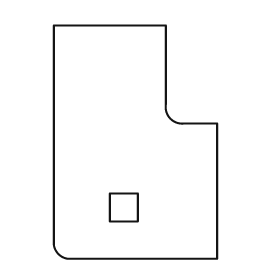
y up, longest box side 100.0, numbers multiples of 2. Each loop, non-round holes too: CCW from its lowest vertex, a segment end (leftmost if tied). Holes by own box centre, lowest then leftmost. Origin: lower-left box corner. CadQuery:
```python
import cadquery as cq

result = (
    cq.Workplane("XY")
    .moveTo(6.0, 0.0)
    .lineTo(70.0, 0.0)
    .lineTo(70.0, 58.0)
    .lineTo(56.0, 58.0)
    .threePointArc((50.0, 60.0), (48.0, 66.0))
    .lineTo(48.0, 100.0)
    .lineTo(0.0, 100.0)
    .lineTo(0.0, 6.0)
    .threePointArc((2.0, 2.0), (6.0, 0.0))
    .close()
    .moveTo(24.0, 16.0)
    .lineTo(36.0, 16.0)
    .lineTo(36.0, 28.0)
    .lineTo(24.0, 28.0)
    .close()
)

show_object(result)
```